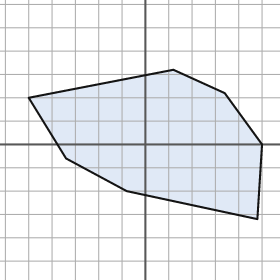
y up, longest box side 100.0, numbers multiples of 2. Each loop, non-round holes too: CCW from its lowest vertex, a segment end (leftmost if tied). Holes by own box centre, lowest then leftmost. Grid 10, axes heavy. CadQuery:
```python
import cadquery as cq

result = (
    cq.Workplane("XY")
    .moveTo(48.0, -32.0)
    .lineTo(50.0, 0.0)
    .lineTo(34.0, 22.0)
    .lineTo(12.0, 32.0)
    .lineTo(-50.0, 20.0)
    .lineTo(-34.0, -6.0)
    .lineTo(-8.0, -20.0)
    .close()
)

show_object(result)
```